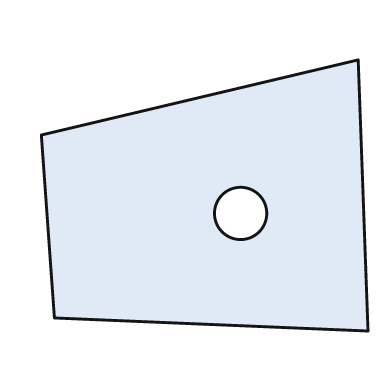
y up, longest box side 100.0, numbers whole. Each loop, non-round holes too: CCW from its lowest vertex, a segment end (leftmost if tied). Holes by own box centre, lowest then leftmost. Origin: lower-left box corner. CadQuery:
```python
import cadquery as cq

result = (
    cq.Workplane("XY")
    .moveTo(100.0, 0.0)
    .lineTo(97.0, 83.0)
    .lineTo(0.0, 60.0)
    .lineTo(4.0, 4.0)
    .close()
    .moveTo(61.0, 36.0)
    .circle(8.0)
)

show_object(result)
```